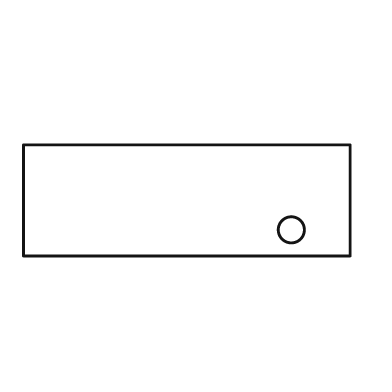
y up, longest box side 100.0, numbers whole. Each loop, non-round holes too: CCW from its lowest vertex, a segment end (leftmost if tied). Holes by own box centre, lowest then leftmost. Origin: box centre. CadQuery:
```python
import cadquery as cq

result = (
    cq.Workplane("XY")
    .moveTo(-50.0, -17.0)
    .lineTo(50.0, -17.0)
    .lineTo(50.0, 17.0)
    .lineTo(-50.0, 17.0)
    .close()
    .moveTo(32.0, -9.0)
    .circle(4.0)
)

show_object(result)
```